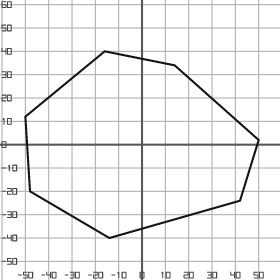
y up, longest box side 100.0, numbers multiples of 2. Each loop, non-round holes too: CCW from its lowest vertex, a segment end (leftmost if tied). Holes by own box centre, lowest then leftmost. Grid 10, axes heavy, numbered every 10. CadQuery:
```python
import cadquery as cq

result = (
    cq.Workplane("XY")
    .moveTo(-14.0, -40.0)
    .lineTo(42.0, -24.0)
    .lineTo(50.0, 2.0)
    .lineTo(14.0, 34.0)
    .lineTo(-16.0, 40.0)
    .lineTo(-50.0, 12.0)
    .lineTo(-48.0, -20.0)
    .close()
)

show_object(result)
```